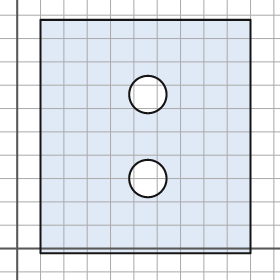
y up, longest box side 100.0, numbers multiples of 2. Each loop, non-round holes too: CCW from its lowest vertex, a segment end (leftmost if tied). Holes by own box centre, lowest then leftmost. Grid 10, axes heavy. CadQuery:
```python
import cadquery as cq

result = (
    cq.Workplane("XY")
    .moveTo(10.0, -2.0)
    .lineTo(100.0, -2.0)
    .lineTo(100.0, 98.0)
    .lineTo(10.0, 98.0)
    .close()
    .moveTo(56.0, 30.0)
    .circle(8.0)
    .moveTo(56.0, 66.0)
    .circle(8.0)
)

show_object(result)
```